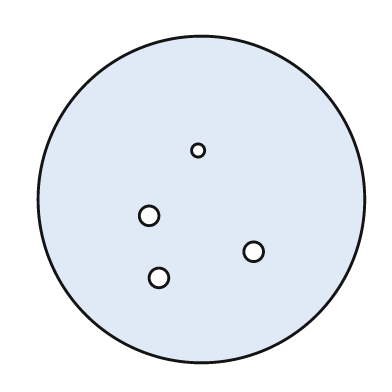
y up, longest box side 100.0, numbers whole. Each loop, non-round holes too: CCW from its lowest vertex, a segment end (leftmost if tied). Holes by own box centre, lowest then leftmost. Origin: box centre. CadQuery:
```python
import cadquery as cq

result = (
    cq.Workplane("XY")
    .moveTo(0.0, 0.0)
    .circle(50.0)
    .moveTo(-13.0, -24.0)
    .circle(3.0)
    .moveTo(16.0, -16.0)
    .circle(3.0)
    .moveTo(-16.0, -5.0)
    .circle(3.0)
    .moveTo(-1.0, 15.0)
    .circle(2.0)
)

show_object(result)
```